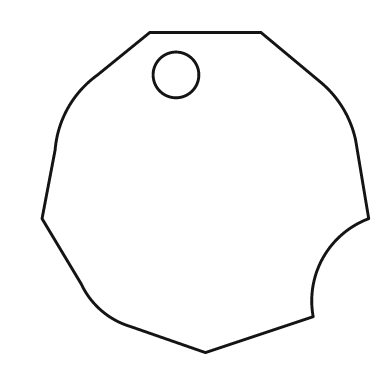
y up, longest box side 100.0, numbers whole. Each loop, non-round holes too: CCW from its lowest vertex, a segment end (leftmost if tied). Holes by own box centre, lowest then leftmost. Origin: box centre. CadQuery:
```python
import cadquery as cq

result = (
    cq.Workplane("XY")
    .moveTo(0.0, -49.0)
    .lineTo(33.0, -38.0)
    .threePointArc((36.0, -20.0), (50.0, -8.0))
    .lineTo(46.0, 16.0)
    .threePointArc((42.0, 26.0), (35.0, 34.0))
    .lineTo(17.0, 49.0)
    .lineTo(-17.0, 49.0)
    .lineTo(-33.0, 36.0)
    .threePointArc((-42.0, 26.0), (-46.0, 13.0))
    .lineTo(-50.0, -8.0)
    .lineTo(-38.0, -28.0)
    .threePointArc((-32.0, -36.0), (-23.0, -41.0))
    .close()
    .moveTo(-9.0, 36.0)
    .circle(7.0)
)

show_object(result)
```